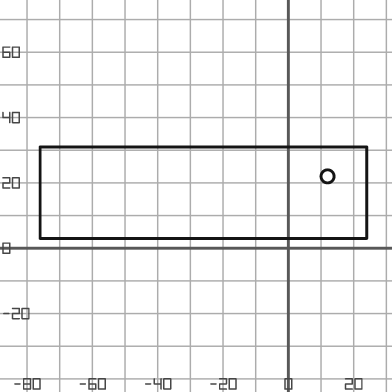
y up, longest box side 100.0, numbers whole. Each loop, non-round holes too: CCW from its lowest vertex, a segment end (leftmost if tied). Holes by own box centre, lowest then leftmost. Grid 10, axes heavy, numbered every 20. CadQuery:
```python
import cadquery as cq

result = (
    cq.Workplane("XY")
    .moveTo(-76.0, 3.0)
    .lineTo(24.0, 3.0)
    .lineTo(24.0, 31.0)
    .lineTo(-76.0, 31.0)
    .close()
    .moveTo(12.0, 22.0)
    .circle(2.0)
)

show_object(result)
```